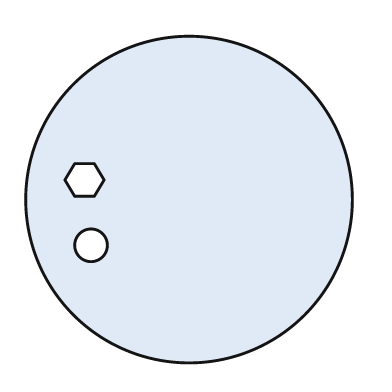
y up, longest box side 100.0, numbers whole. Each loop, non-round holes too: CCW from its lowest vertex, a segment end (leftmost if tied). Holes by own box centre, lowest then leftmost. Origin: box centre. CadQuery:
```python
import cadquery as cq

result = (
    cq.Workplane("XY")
    .moveTo(0.0, 0.0)
    .circle(50.0)
    .moveTo(-30.0, -14.0)
    .circle(5.0)
    .moveTo(-35.0, 1.0)
    .lineTo(-29.0, 1.0)
    .lineTo(-26.0, 6.0)
    .lineTo(-29.0, 11.0)
    .lineTo(-35.0, 11.0)
    .lineTo(-38.0, 6.0)
    .close()
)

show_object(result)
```